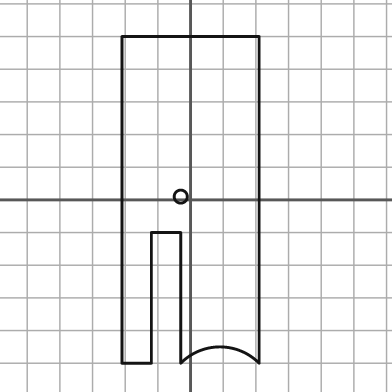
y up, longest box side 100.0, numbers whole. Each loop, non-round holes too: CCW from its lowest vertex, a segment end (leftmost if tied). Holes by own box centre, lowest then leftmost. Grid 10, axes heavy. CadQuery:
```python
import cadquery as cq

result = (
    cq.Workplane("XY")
    .moveTo(-21.0, -50.0)
    .lineTo(-12.0, -50.0)
    .lineTo(-12.0, -10.0)
    .lineTo(-3.0, -10.0)
    .lineTo(-3.0, -50.0)
    .threePointArc((9.0, -45.0), (21.0, -50.0))
    .lineTo(21.0, 50.0)
    .lineTo(-21.0, 50.0)
    .close()
    .moveTo(-3.0, 1.0)
    .circle(2.0)
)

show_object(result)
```